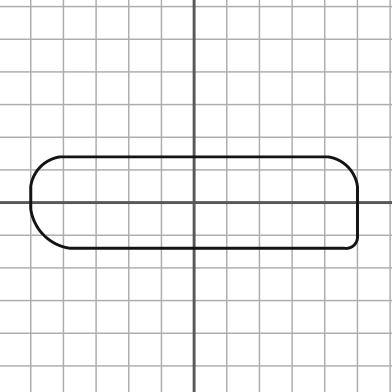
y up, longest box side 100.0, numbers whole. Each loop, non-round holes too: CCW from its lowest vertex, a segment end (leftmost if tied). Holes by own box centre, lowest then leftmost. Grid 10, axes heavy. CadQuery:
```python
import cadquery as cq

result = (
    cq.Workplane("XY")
    .moveTo(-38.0, -14.0)
    .lineTo(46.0, -14.0)
    .threePointArc((49.0, -13.0), (50.0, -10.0))
    .lineTo(50.0, 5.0)
    .threePointArc((47.0, 11.0), (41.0, 14.0))
    .lineTo(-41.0, 14.0)
    .threePointArc((-47.0, 11.0), (-50.0, 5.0))
    .lineTo(-50.0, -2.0)
    .threePointArc((-46.0, -10.0), (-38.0, -14.0))
    .close()
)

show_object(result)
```